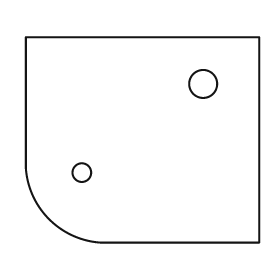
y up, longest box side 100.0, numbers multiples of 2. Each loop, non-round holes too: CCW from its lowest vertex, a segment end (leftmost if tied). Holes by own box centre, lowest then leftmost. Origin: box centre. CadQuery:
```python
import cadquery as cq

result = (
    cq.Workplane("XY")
    .moveTo(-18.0, -44.0)
    .lineTo(50.0, -44.0)
    .lineTo(50.0, 44.0)
    .lineTo(-50.0, 44.0)
    .lineTo(-50.0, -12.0)
    .threePointArc((-40.0, -34.0), (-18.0, -44.0))
    .close()
    .moveTo(-26.0, -14.0)
    .circle(4.0)
    .moveTo(26.0, 24.0)
    .circle(6.0)
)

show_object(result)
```